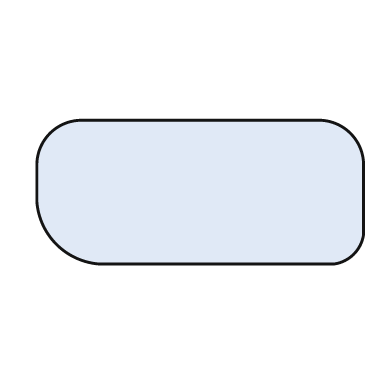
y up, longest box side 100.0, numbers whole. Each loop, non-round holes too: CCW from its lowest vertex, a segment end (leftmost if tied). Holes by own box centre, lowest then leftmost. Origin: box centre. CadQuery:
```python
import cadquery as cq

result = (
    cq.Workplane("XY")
    .moveTo(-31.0, -22.0)
    .lineTo(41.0, -22.0)
    .threePointArc((47.0, -19.0), (50.0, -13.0))
    .lineTo(50.0, 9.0)
    .threePointArc((46.0, 18.0), (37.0, 22.0))
    .lineTo(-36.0, 22.0)
    .threePointArc((-46.0, 18.0), (-50.0, 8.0))
    .lineTo(-50.0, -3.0)
    .threePointArc((-44.0, -16.0), (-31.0, -22.0))
    .close()
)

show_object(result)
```